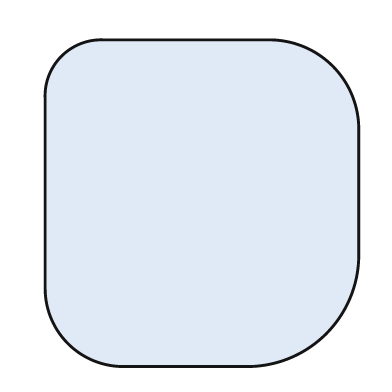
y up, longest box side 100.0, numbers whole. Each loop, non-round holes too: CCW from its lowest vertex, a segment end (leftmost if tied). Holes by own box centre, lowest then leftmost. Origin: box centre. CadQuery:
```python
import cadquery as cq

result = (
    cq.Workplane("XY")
    .moveTo(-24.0, -50.0)
    .lineTo(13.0, -50.0)
    .threePointArc((38.0, -40.0), (48.0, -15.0))
    .lineTo(48.0, 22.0)
    .threePointArc((40.0, 42.0), (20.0, 50.0))
    .lineTo(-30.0, 50.0)
    .threePointArc((-43.0, 45.0), (-48.0, 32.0))
    .lineTo(-48.0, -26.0)
    .threePointArc((-41.0, -43.0), (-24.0, -50.0))
    .close()
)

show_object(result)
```